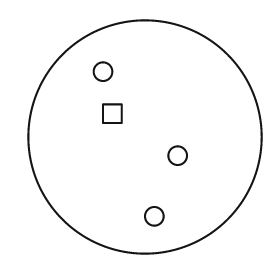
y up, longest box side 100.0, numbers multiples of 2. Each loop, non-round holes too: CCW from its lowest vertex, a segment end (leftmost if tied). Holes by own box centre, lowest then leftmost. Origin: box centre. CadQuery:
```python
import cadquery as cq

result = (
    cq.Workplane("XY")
    .moveTo(0.0, 0.0)
    .circle(50.0)
    .moveTo(4.0, -34.0)
    .circle(4.0)
    .moveTo(14.0, -8.0)
    .circle(4.0)
    .moveTo(-18.0, 6.0)
    .lineTo(-10.0, 6.0)
    .lineTo(-10.0, 14.0)
    .lineTo(-18.0, 14.0)
    .close()
    .moveTo(-18.0, 28.0)
    .circle(4.0)
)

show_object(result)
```